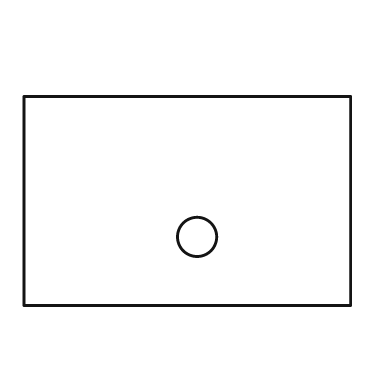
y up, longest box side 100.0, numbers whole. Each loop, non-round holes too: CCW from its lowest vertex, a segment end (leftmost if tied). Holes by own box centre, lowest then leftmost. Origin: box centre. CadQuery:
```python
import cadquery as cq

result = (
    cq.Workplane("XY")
    .moveTo(-50.0, -32.0)
    .lineTo(50.0, -32.0)
    .lineTo(50.0, 32.0)
    .lineTo(-50.0, 32.0)
    .close()
    .moveTo(3.0, -11.0)
    .circle(6.0)
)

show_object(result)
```